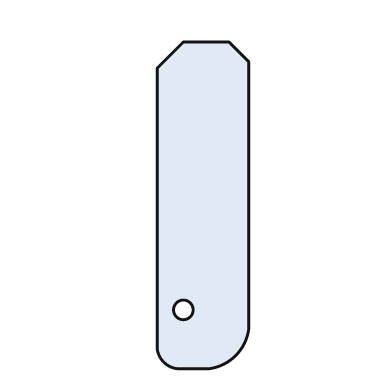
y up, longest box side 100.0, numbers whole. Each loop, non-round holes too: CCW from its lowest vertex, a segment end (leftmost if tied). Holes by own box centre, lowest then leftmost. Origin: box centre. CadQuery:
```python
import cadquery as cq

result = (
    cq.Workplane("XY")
    .moveTo(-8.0, -50.0)
    .lineTo(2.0, -50.0)
    .threePointArc((10.0, -46.0), (14.0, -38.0))
    .lineTo(14.0, 44.0)
    .lineTo(8.0, 50.0)
    .lineTo(-6.0, 50.0)
    .lineTo(-14.0, 42.0)
    .lineTo(-14.0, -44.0)
    .threePointArc((-12.0, -48.0), (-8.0, -50.0))
    .close()
    .moveTo(-6.0, -32.0)
    .circle(3.0)
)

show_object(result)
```